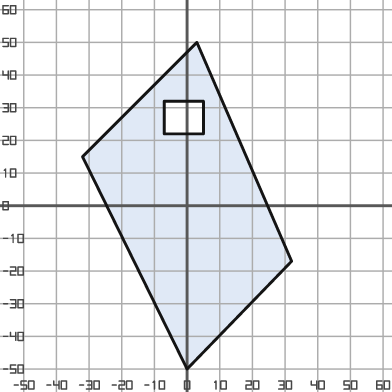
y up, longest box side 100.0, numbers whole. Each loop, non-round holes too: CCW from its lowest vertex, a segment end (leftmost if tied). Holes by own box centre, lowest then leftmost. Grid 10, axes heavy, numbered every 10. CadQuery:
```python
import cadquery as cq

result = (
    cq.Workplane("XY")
    .moveTo(0.0, -50.0)
    .lineTo(32.0, -17.0)
    .lineTo(3.0, 50.0)
    .lineTo(-32.0, 15.0)
    .close()
    .moveTo(-7.0, 22.0)
    .lineTo(5.0, 22.0)
    .lineTo(5.0, 32.0)
    .lineTo(-7.0, 32.0)
    .close()
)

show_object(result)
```